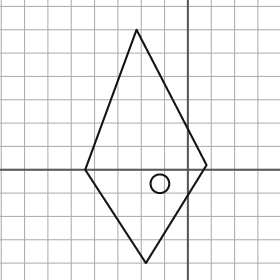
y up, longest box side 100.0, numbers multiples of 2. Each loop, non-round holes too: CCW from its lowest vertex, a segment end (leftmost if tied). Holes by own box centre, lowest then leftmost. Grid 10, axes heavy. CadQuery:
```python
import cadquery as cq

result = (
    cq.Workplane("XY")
    .moveTo(-18.0, -40.0)
    .lineTo(8.0, 2.0)
    .lineTo(-22.0, 60.0)
    .lineTo(-44.0, 0.0)
    .close()
    .moveTo(-12.0, -6.0)
    .circle(4.0)
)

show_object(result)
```